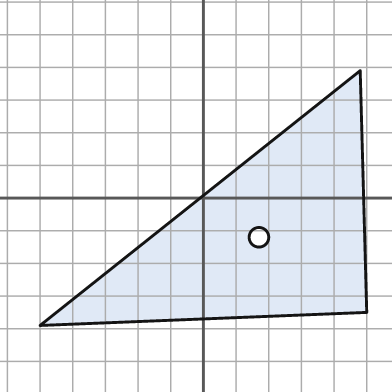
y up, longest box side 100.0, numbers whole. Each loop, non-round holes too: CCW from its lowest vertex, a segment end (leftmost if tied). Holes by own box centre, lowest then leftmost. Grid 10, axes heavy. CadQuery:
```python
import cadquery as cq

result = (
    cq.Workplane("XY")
    .moveTo(-50.0, -39.0)
    .lineTo(50.0, -35.0)
    .lineTo(48.0, 39.0)
    .close()
    .moveTo(17.0, -12.0)
    .circle(3.0)
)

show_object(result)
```